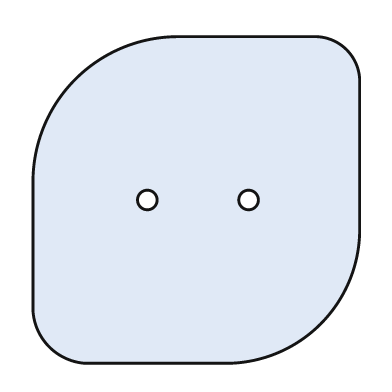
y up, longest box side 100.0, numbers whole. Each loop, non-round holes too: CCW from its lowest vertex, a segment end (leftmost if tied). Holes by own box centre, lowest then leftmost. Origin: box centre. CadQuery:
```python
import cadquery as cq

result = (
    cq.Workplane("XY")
    .moveTo(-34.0, -50.0)
    .lineTo(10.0, -50.0)
    .threePointArc((38.0, -38.0), (50.0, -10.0))
    .lineTo(50.0, 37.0)
    .threePointArc((46.0, 46.0), (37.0, 50.0))
    .lineTo(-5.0, 50.0)
    .threePointArc((-37.0, 37.0), (-50.0, 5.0))
    .lineTo(-50.0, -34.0)
    .threePointArc((-45.0, -45.0), (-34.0, -50.0))
    .close()
    .moveTo(-15.0, 0.0)
    .circle(3.0)
    .moveTo(16.0, 0.0)
    .circle(3.0)
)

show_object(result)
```